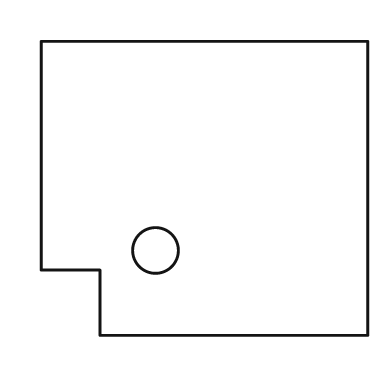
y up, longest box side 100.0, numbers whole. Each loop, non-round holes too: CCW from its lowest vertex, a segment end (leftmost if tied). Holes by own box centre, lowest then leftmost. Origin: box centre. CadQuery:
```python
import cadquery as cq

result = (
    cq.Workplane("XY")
    .moveTo(-32.0, -45.0)
    .lineTo(50.0, -45.0)
    .lineTo(50.0, 45.0)
    .lineTo(-50.0, 45.0)
    .lineTo(-50.0, -25.0)
    .lineTo(-32.0, -25.0)
    .close()
    .moveTo(-15.0, -19.0)
    .circle(7.0)
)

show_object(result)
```